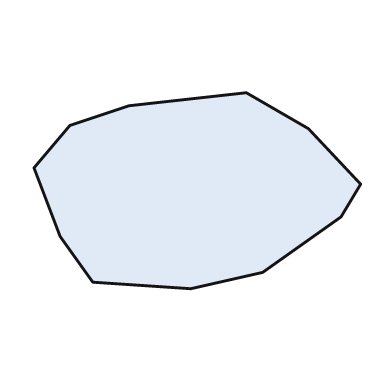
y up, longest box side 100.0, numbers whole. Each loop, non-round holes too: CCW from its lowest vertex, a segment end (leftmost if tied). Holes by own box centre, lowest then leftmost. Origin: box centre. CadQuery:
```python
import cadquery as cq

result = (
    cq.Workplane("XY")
    .moveTo(-2.0, -30.0)
    .lineTo(20.0, -25.0)
    .lineTo(44.0, -8.0)
    .lineTo(50.0, 2.0)
    .lineTo(34.0, 19.0)
    .lineTo(15.0, 30.0)
    .lineTo(-21.0, 26.0)
    .lineTo(-39.0, 20.0)
    .lineTo(-50.0, 7.0)
    .lineTo(-42.0, -14.0)
    .lineTo(-32.0, -28.0)
    .close()
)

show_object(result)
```